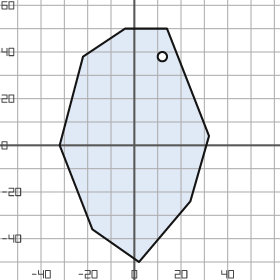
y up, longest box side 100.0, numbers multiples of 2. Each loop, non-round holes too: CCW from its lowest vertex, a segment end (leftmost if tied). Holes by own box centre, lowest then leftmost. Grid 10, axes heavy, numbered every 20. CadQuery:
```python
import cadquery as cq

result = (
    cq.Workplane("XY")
    .moveTo(2.0, -50.0)
    .lineTo(24.0, -24.0)
    .lineTo(32.0, 4.0)
    .lineTo(14.0, 50.0)
    .lineTo(-4.0, 50.0)
    .lineTo(-22.0, 38.0)
    .lineTo(-32.0, 0.0)
    .lineTo(-18.0, -36.0)
    .close()
    .moveTo(12.0, 38.0)
    .circle(2.0)
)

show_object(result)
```